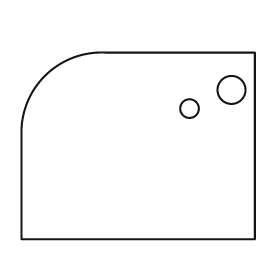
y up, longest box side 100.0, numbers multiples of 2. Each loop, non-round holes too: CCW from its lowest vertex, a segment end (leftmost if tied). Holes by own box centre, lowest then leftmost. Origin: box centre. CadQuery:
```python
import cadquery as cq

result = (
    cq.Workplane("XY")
    .moveTo(-50.0, -40.0)
    .lineTo(50.0, -40.0)
    .lineTo(50.0, 40.0)
    .lineTo(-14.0, 40.0)
    .threePointArc((-40.0, 30.0), (-50.0, 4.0))
    .close()
    .moveTo(22.0, 16.0)
    .circle(4.0)
    .moveTo(40.0, 24.0)
    .circle(6.0)
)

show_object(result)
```